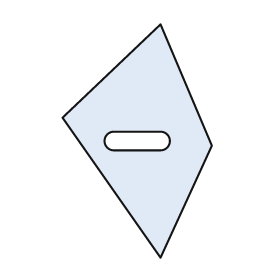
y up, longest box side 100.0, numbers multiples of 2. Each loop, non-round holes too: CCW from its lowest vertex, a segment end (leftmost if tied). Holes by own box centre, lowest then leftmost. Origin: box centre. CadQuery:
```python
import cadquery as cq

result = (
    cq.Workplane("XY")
    .moveTo(10.0, -50.0)
    .lineTo(32.0, -2.0)
    .lineTo(10.0, 50.0)
    .lineTo(-32.0, 10.0)
    .close()
    .moveTo(-10.0, -4.0)
    .lineTo(10.0, -4.0)
    .threePointArc((14.0, 0.0), (10.0, 4.0))
    .lineTo(-10.0, 4.0)
    .threePointArc((-14.0, 0.0), (-10.0, -4.0))
    .close()
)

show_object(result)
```